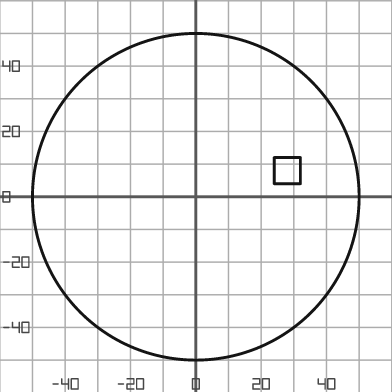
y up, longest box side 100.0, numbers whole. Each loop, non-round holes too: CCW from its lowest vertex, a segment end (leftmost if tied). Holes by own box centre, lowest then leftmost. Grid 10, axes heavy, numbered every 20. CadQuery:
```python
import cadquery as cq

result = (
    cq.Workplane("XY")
    .moveTo(0.0, 0.0)
    .circle(50.0)
    .moveTo(24.0, 4.0)
    .lineTo(32.0, 4.0)
    .lineTo(32.0, 12.0)
    .lineTo(24.0, 12.0)
    .close()
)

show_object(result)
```